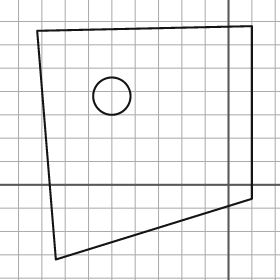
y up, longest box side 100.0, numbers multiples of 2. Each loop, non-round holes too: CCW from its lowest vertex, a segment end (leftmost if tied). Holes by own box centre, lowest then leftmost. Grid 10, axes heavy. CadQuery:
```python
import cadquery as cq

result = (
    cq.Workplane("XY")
    .moveTo(-74.0, -32.0)
    .lineTo(10.0, -6.0)
    .lineTo(10.0, 68.0)
    .lineTo(-82.0, 66.0)
    .close()
    .moveTo(-50.0, 38.0)
    .circle(8.0)
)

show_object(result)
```